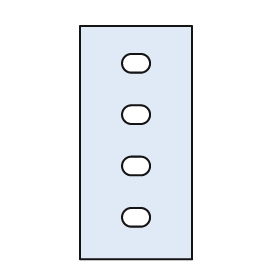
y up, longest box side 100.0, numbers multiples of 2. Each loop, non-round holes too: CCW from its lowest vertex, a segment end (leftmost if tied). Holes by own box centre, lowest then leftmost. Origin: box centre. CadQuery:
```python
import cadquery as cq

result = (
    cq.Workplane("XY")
    .moveTo(-24.0, -50.0)
    .lineTo(24.0, -50.0)
    .lineTo(24.0, 50.0)
    .lineTo(-24.0, 50.0)
    .close()
    .moveTo(-2.0, -36.0)
    .lineTo(2.0, -36.0)
    .threePointArc((6.0, -32.0), (2.0, -28.0))
    .lineTo(-2.0, -28.0)
    .threePointArc((-6.0, -32.0), (-2.0, -36.0))
    .close()
    .moveTo(-2.0, -14.0)
    .lineTo(2.0, -14.0)
    .threePointArc((6.0, -10.0), (2.0, -6.0))
    .lineTo(-2.0, -6.0)
    .threePointArc((-6.0, -10.0), (-2.0, -14.0))
    .close()
    .moveTo(-2.0, 8.0)
    .lineTo(2.0, 8.0)
    .threePointArc((6.0, 12.0), (2.0, 16.0))
    .lineTo(-2.0, 16.0)
    .threePointArc((-6.0, 12.0), (-2.0, 8.0))
    .close()
    .moveTo(-2.0, 30.0)
    .lineTo(2.0, 30.0)
    .threePointArc((6.0, 34.0), (2.0, 38.0))
    .lineTo(-2.0, 38.0)
    .threePointArc((-6.0, 34.0), (-2.0, 30.0))
    .close()
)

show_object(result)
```